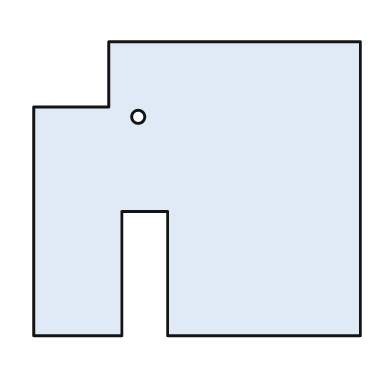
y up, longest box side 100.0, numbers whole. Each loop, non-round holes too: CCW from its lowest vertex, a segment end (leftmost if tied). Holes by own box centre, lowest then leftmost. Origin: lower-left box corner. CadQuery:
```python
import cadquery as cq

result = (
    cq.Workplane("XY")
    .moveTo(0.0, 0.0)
    .lineTo(27.0, 0.0)
    .lineTo(27.0, 38.0)
    .lineTo(41.0, 38.0)
    .lineTo(41.0, 0.0)
    .lineTo(100.0, 0.0)
    .lineTo(100.0, 90.0)
    .lineTo(23.0, 90.0)
    .lineTo(23.0, 70.0)
    .lineTo(0.0, 70.0)
    .close()
    .moveTo(32.0, 67.0)
    .circle(2.0)
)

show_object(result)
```